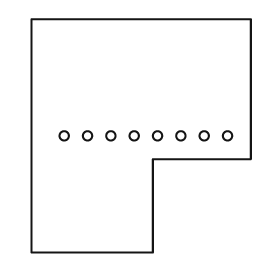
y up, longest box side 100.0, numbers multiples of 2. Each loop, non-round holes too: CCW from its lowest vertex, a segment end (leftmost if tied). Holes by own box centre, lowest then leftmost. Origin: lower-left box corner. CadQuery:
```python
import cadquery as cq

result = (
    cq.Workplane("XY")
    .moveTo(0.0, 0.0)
    .lineTo(52.0, 0.0)
    .lineTo(52.0, 40.0)
    .lineTo(94.0, 40.0)
    .lineTo(94.0, 100.0)
    .lineTo(0.0, 100.0)
    .close()
    .moveTo(14.0, 50.0)
    .circle(2.0)
    .moveTo(24.0, 50.0)
    .circle(2.0)
    .moveTo(34.0, 50.0)
    .circle(2.0)
    .moveTo(44.0, 50.0)
    .circle(2.0)
    .moveTo(54.0, 50.0)
    .circle(2.0)
    .moveTo(64.0, 50.0)
    .circle(2.0)
    .moveTo(74.0, 50.0)
    .circle(2.0)
    .moveTo(84.0, 50.0)
    .circle(2.0)
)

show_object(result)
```